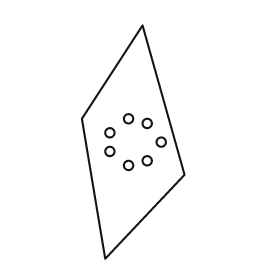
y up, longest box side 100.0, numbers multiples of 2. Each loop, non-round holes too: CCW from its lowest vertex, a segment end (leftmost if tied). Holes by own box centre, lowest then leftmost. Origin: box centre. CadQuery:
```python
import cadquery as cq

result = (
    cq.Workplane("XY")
    .moveTo(-12.0, -50.0)
    .lineTo(22.0, -14.0)
    .lineTo(4.0, 50.0)
    .lineTo(-22.0, 10.0)
    .close()
    .moveTo(-2.0, -10.0)
    .circle(2.0)
    .moveTo(6.0, -8.0)
    .circle(2.0)
    .moveTo(-10.0, -4.0)
    .circle(2.0)
    .moveTo(12.0, 0.0)
    .circle(2.0)
    .moveTo(-10.0, 4.0)
    .circle(2.0)
    .moveTo(6.0, 8.0)
    .circle(2.0)
    .moveTo(-2.0, 10.0)
    .circle(2.0)
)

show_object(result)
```